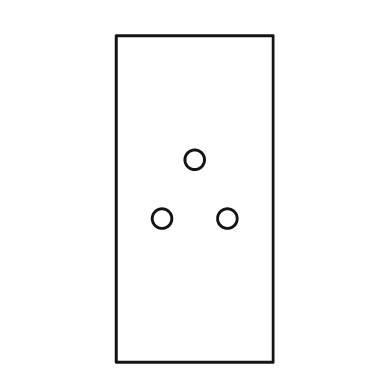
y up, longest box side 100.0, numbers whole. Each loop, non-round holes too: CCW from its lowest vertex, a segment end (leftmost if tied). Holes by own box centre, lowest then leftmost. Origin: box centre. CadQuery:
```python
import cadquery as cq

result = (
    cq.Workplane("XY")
    .moveTo(-24.0, -50.0)
    .lineTo(24.0, -50.0)
    .lineTo(24.0, 50.0)
    .lineTo(-24.0, 50.0)
    .close()
    .moveTo(-10.0, -6.0)
    .circle(3.0)
    .moveTo(10.0, -6.0)
    .circle(3.0)
    .moveTo(0.0, 12.0)
    .circle(3.0)
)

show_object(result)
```